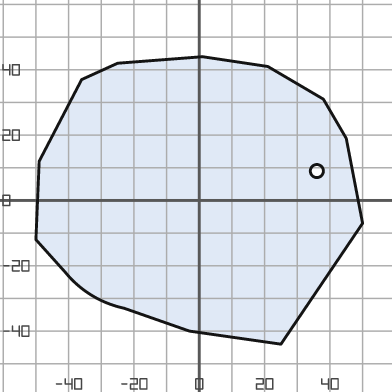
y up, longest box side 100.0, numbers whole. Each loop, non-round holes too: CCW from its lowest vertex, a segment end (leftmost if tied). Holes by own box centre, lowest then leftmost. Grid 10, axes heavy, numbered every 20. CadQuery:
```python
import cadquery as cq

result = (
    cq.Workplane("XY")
    .moveTo(25.0, -44.0)
    .lineTo(50.0, -7.0)
    .lineTo(45.0, 19.0)
    .lineTo(38.0, 31.0)
    .lineTo(21.0, 41.0)
    .lineTo(1.0, 44.0)
    .lineTo(-25.0, 42.0)
    .lineTo(-36.0, 37.0)
    .lineTo(-49.0, 12.0)
    .lineTo(-50.0, -12.0)
    .lineTo(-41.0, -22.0)
    .threePointArc((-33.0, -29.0), (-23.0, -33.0))
    .lineTo(-3.0, -40.0)
    .close()
    .moveTo(36.0, 9.0)
    .circle(2.0)
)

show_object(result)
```